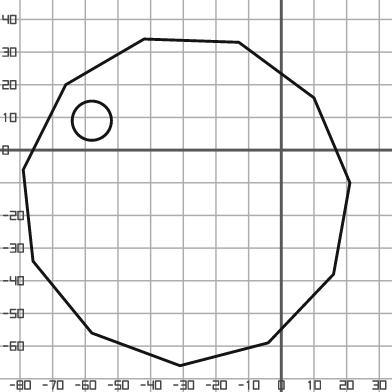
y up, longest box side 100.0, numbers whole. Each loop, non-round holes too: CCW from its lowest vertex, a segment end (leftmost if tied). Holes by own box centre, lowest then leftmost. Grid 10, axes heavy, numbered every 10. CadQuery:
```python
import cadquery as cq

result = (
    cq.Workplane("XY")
    .moveTo(-31.0, -66.0)
    .lineTo(-4.0, -59.0)
    .lineTo(16.0, -38.0)
    .lineTo(21.0, -10.0)
    .lineTo(10.0, 16.0)
    .lineTo(-13.0, 33.0)
    .lineTo(-42.0, 34.0)
    .lineTo(-66.0, 20.0)
    .lineTo(-79.0, -6.0)
    .lineTo(-76.0, -34.0)
    .lineTo(-58.0, -56.0)
    .close()
    .moveTo(-58.0, 9.0)
    .circle(6.0)
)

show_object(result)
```